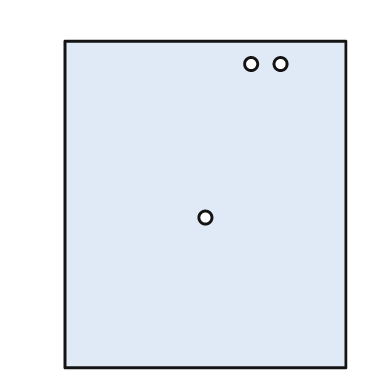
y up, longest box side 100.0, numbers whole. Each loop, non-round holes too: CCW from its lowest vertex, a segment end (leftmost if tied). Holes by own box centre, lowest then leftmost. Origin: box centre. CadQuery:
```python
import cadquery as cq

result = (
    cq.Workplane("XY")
    .moveTo(-43.0, -50.0)
    .lineTo(43.0, -50.0)
    .lineTo(43.0, 50.0)
    .lineTo(-43.0, 50.0)
    .close()
    .moveTo(0.0, -4.0)
    .circle(2.0)
    .moveTo(14.0, 43.0)
    .circle(2.0)
    .moveTo(23.0, 43.0)
    .circle(2.0)
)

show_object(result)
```